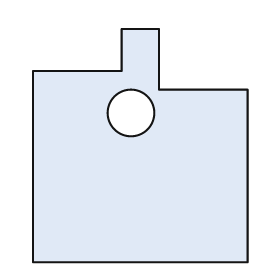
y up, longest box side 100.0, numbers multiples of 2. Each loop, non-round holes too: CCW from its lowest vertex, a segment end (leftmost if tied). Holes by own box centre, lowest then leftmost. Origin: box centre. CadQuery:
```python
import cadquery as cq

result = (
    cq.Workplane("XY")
    .moveTo(-46.0, -50.0)
    .lineTo(46.0, -50.0)
    .lineTo(46.0, 24.0)
    .lineTo(8.0, 24.0)
    .lineTo(8.0, 50.0)
    .lineTo(-8.0, 50.0)
    .lineTo(-8.0, 32.0)
    .lineTo(-46.0, 32.0)
    .close()
    .moveTo(-4.0, 14.0)
    .circle(10.0)
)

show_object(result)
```